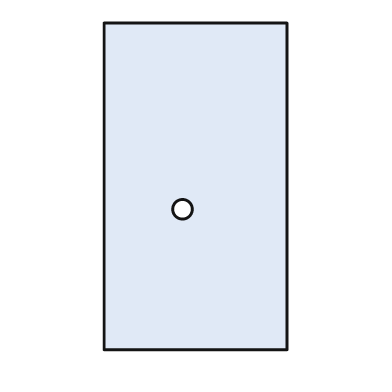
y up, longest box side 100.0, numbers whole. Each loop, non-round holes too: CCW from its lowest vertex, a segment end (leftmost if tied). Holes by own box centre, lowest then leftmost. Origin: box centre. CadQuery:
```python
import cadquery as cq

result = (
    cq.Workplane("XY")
    .moveTo(-28.0, -50.0)
    .lineTo(28.0, -50.0)
    .lineTo(28.0, 50.0)
    .lineTo(-28.0, 50.0)
    .close()
    .moveTo(-4.0, -7.0)
    .circle(3.0)
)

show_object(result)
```